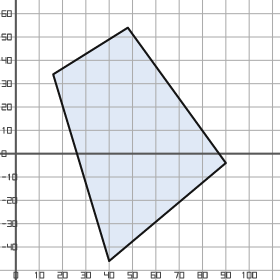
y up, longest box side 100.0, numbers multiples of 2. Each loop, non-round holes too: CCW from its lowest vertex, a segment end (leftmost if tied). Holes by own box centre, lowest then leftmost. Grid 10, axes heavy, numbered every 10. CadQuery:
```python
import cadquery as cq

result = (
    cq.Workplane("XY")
    .moveTo(40.0, -46.0)
    .lineTo(90.0, -4.0)
    .lineTo(48.0, 54.0)
    .lineTo(16.0, 34.0)
    .close()
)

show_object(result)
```